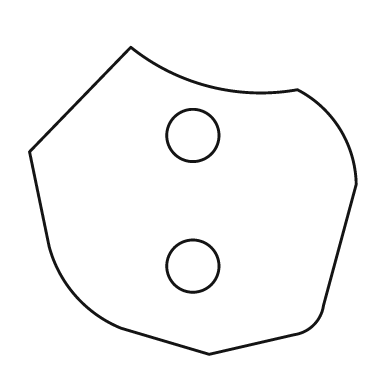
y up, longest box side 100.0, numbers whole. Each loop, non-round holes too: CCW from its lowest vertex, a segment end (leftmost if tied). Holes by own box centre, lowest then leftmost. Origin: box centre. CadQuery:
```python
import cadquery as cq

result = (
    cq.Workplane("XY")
    .moveTo(5.0, -47.0)
    .lineTo(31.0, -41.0)
    .threePointArc((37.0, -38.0), (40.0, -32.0))
    .lineTo(50.0, 5.0)
    .threePointArc((45.0, 22.0), (32.0, 34.0))
    .threePointArc((5.0, 35.0), (-19.0, 47.0))
    .lineTo(-50.0, 15.0)
    .lineTo(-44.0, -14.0)
    .threePointArc((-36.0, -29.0), (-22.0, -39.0))
    .close()
    .moveTo(0.0, -20.0)
    .circle(8.0)
    .moveTo(0.0, 20.0)
    .circle(8.0)
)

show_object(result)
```